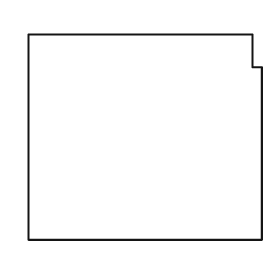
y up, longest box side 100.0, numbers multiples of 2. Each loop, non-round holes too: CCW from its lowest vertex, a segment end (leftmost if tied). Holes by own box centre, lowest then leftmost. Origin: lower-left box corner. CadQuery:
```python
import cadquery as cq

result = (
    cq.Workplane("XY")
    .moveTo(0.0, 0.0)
    .lineTo(100.0, 0.0)
    .lineTo(100.0, 74.0)
    .lineTo(96.0, 74.0)
    .lineTo(96.0, 88.0)
    .lineTo(0.0, 88.0)
    .close()
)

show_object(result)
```